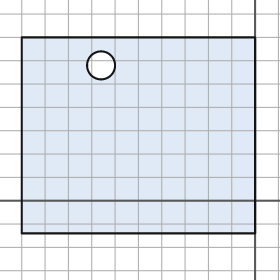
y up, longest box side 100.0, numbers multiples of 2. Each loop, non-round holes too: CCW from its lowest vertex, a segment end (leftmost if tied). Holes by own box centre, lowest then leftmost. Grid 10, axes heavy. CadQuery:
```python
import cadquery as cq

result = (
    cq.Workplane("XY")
    .moveTo(-100.0, -14.0)
    .lineTo(0.0, -14.0)
    .lineTo(0.0, 70.0)
    .lineTo(-100.0, 70.0)
    .close()
    .moveTo(-66.0, 58.0)
    .circle(6.0)
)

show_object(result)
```